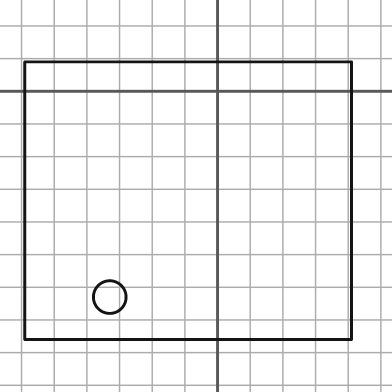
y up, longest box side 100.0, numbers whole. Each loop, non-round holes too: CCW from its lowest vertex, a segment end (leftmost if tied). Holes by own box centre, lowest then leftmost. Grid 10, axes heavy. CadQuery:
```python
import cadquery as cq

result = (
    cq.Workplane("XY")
    .moveTo(-59.0, -76.0)
    .lineTo(41.0, -76.0)
    .lineTo(41.0, 9.0)
    .lineTo(-59.0, 9.0)
    .close()
    .moveTo(-33.0, -63.0)
    .circle(5.0)
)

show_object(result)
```